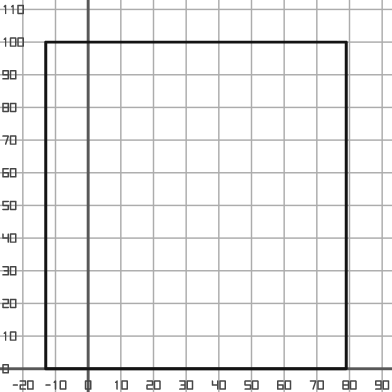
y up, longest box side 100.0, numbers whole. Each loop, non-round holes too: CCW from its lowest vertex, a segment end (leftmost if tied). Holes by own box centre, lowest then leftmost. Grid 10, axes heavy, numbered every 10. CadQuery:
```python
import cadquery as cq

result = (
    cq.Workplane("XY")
    .moveTo(-13.0, 0.0)
    .lineTo(79.0, 0.0)
    .lineTo(79.0, 100.0)
    .lineTo(-13.0, 100.0)
    .close()
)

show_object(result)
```